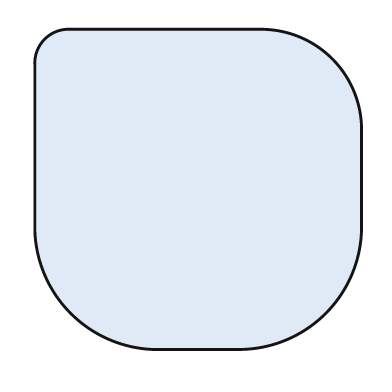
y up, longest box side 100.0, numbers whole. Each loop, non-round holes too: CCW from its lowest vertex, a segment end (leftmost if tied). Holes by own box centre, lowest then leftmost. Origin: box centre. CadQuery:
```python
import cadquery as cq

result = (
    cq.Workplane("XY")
    .moveTo(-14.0, -49.0)
    .lineTo(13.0, -49.0)
    .threePointArc((39.0, -38.0), (50.0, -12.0))
    .lineTo(50.0, 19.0)
    .threePointArc((41.0, 40.0), (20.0, 49.0))
    .lineTo(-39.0, 49.0)
    .threePointArc((-47.0, 46.0), (-50.0, 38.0))
    .lineTo(-50.0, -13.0)
    .threePointArc((-39.0, -38.0), (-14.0, -49.0))
    .close()
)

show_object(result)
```